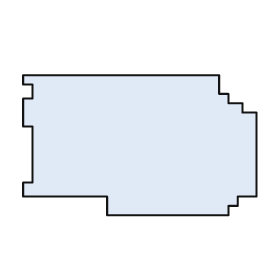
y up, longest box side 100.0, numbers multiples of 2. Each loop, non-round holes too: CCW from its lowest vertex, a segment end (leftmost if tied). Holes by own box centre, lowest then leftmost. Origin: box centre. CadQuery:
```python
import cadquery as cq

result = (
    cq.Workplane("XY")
    .moveTo(-14.0, -30.0)
    .lineTo(38.0, -30.0)
    .lineTo(38.0, -26.0)
    .lineTo(42.0, -26.0)
    .lineTo(42.0, -22.0)
    .lineTo(50.0, -22.0)
    .lineTo(50.0, 14.0)
    .lineTo(44.0, 14.0)
    .lineTo(44.0, 18.0)
    .lineTo(38.0, 18.0)
    .lineTo(38.0, 22.0)
    .lineTo(34.0, 22.0)
    .lineTo(34.0, 30.0)
    .lineTo(-50.0, 30.0)
    .lineTo(-50.0, 26.0)
    .lineTo(-46.0, 26.0)
    .lineTo(-46.0, 20.0)
    .lineTo(-50.0, 20.0)
    .lineTo(-50.0, 8.0)
    .lineTo(-46.0, 8.0)
    .lineTo(-46.0, -16.0)
    .lineTo(-50.0, -16.0)
    .lineTo(-50.0, -22.0)
    .lineTo(-14.0, -22.0)
    .close()
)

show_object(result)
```